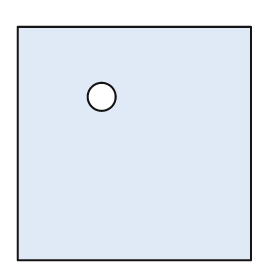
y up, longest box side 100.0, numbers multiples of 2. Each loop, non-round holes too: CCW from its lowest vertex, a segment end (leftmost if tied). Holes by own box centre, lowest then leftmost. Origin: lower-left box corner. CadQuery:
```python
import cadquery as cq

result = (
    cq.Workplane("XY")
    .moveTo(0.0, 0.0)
    .lineTo(100.0, 0.0)
    .lineTo(100.0, 100.0)
    .lineTo(0.0, 100.0)
    .close()
    .moveTo(36.0, 70.0)
    .circle(6.0)
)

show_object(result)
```